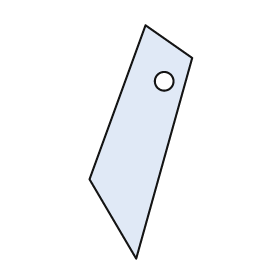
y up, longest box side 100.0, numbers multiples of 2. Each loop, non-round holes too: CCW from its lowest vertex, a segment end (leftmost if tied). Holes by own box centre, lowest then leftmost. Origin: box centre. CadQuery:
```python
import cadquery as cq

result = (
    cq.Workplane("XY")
    .moveTo(-2.0, -50.0)
    .lineTo(22.0, 36.0)
    .lineTo(2.0, 50.0)
    .lineTo(-22.0, -16.0)
    .close()
    .moveTo(10.0, 26.0)
    .circle(4.0)
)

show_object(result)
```